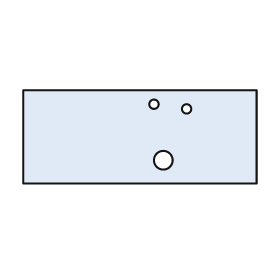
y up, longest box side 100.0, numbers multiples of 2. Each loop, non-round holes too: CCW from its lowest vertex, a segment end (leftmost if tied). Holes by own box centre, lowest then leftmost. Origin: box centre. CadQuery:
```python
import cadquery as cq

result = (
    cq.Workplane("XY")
    .moveTo(-50.0, -20.0)
    .lineTo(50.0, -20.0)
    .lineTo(50.0, 20.0)
    .lineTo(-50.0, 20.0)
    .close()
    .moveTo(10.0, -10.0)
    .circle(4.0)
    .moveTo(20.0, 12.0)
    .circle(2.0)
    .moveTo(6.0, 14.0)
    .circle(2.0)
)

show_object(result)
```